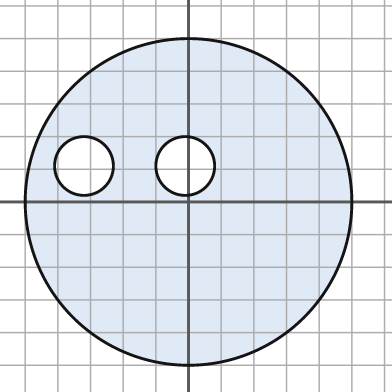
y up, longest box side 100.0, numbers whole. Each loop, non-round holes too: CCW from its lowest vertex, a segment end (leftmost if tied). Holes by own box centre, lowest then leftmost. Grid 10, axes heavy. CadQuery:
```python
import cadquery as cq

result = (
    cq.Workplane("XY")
    .moveTo(0.0, 0.0)
    .circle(50.0)
    .moveTo(-32.0, 11.0)
    .circle(9.0)
    .moveTo(-1.0, 11.0)
    .circle(9.0)
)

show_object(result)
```